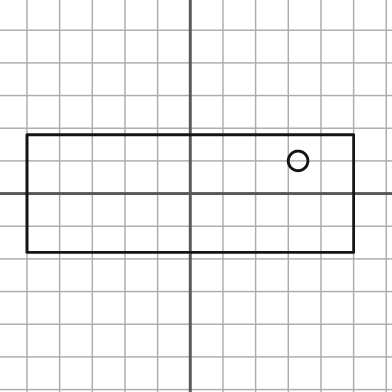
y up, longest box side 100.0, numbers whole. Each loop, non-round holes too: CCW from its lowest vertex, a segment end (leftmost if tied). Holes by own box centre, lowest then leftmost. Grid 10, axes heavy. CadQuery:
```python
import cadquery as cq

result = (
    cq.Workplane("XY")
    .moveTo(-50.0, -18.0)
    .lineTo(50.0, -18.0)
    .lineTo(50.0, 18.0)
    .lineTo(-50.0, 18.0)
    .close()
    .moveTo(33.0, 10.0)
    .circle(3.0)
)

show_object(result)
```